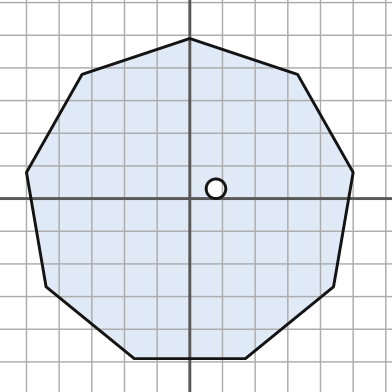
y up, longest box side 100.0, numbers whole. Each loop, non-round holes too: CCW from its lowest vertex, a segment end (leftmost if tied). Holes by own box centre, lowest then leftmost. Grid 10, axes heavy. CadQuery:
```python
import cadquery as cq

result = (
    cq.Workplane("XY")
    .moveTo(-17.0, -49.0)
    .lineTo(17.0, -49.0)
    .lineTo(44.0, -27.0)
    .lineTo(50.0, 8.0)
    .lineTo(33.0, 38.0)
    .lineTo(0.0, 49.0)
    .lineTo(-33.0, 38.0)
    .lineTo(-50.0, 8.0)
    .lineTo(-44.0, -27.0)
    .close()
    .moveTo(8.0, 3.0)
    .circle(3.0)
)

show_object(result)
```